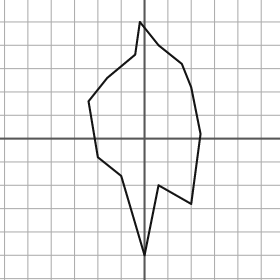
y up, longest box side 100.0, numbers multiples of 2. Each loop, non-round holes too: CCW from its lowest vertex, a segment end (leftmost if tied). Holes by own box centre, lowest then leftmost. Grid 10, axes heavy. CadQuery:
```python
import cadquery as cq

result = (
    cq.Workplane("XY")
    .moveTo(0.0, -50.0)
    .lineTo(6.0, -20.0)
    .lineTo(20.0, -28.0)
    .lineTo(24.0, 2.0)
    .lineTo(20.0, 22.0)
    .lineTo(16.0, 32.0)
    .lineTo(6.0, 40.0)
    .lineTo(-2.0, 50.0)
    .lineTo(-4.0, 36.0)
    .lineTo(-16.0, 26.0)
    .lineTo(-24.0, 16.0)
    .lineTo(-20.0, -8.0)
    .lineTo(-10.0, -16.0)
    .close()
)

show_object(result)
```